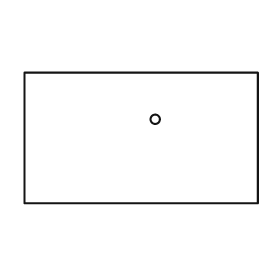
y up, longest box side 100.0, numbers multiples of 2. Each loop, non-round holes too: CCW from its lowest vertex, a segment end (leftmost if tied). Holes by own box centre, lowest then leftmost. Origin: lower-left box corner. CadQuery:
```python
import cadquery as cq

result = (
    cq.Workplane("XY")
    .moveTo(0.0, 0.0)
    .lineTo(100.0, 0.0)
    .lineTo(100.0, 56.0)
    .lineTo(0.0, 56.0)
    .close()
    .moveTo(56.0, 36.0)
    .circle(2.0)
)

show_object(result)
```